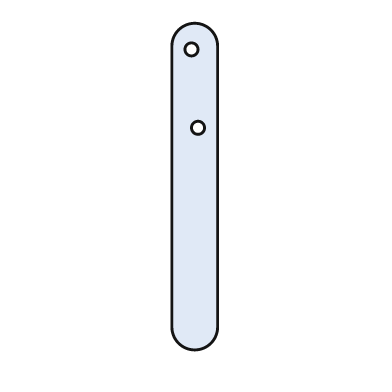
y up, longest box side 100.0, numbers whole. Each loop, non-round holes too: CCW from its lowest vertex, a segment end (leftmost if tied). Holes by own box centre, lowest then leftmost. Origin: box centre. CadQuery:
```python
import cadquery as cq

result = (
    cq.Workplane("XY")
    .moveTo(-7.0, -43.0)
    .threePointArc((0.0, -50.0), (7.0, -43.0))
    .lineTo(7.0, 43.0)
    .threePointArc((0.0, 50.0), (-7.0, 43.0))
    .close()
    .moveTo(1.0, 18.0)
    .circle(2.0)
    .moveTo(-1.0, 42.0)
    .circle(2.0)
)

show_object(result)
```